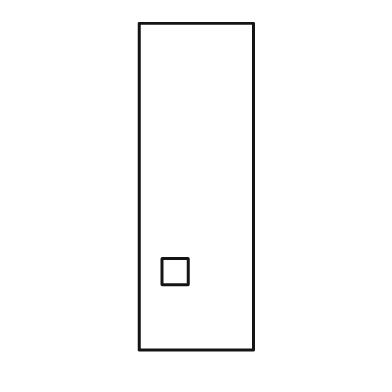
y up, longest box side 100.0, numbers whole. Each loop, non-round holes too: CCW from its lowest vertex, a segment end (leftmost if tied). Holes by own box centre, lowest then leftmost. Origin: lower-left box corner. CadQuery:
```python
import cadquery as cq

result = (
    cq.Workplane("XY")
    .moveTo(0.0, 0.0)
    .lineTo(35.0, 0.0)
    .lineTo(35.0, 100.0)
    .lineTo(0.0, 100.0)
    .close()
    .moveTo(7.0, 20.0)
    .lineTo(15.0, 20.0)
    .lineTo(15.0, 28.0)
    .lineTo(7.0, 28.0)
    .close()
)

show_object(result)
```